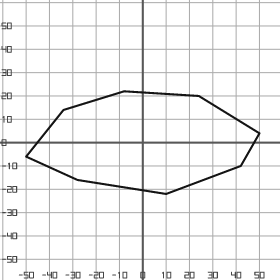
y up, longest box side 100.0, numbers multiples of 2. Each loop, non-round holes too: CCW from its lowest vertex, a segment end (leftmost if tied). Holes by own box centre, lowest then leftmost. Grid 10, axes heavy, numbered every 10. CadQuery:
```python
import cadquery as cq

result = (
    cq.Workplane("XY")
    .moveTo(10.0, -22.0)
    .lineTo(42.0, -10.0)
    .lineTo(50.0, 4.0)
    .lineTo(24.0, 20.0)
    .lineTo(-8.0, 22.0)
    .lineTo(-34.0, 14.0)
    .lineTo(-50.0, -6.0)
    .lineTo(-28.0, -16.0)
    .close()
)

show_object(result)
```